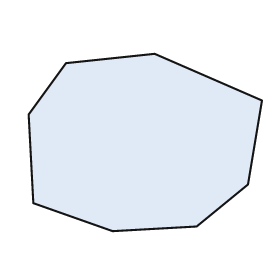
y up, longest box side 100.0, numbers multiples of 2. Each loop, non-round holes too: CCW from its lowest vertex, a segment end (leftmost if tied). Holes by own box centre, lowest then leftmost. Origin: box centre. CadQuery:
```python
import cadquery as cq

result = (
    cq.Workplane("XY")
    .moveTo(-14.0, -38.0)
    .lineTo(22.0, -36.0)
    .lineTo(44.0, -18.0)
    .lineTo(50.0, 18.0)
    .lineTo(4.0, 38.0)
    .lineTo(-34.0, 34.0)
    .lineTo(-50.0, 12.0)
    .lineTo(-48.0, -26.0)
    .close()
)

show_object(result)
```